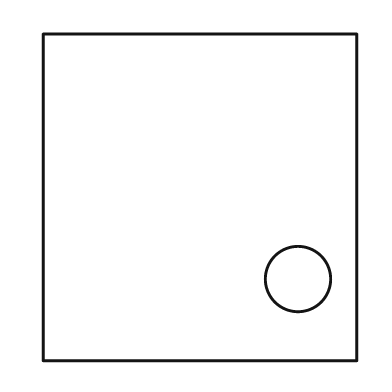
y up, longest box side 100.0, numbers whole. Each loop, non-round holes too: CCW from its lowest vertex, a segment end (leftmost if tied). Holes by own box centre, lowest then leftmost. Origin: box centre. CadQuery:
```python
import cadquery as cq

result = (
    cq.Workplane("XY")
    .moveTo(-48.0, -50.0)
    .lineTo(48.0, -50.0)
    .lineTo(48.0, 50.0)
    .lineTo(-48.0, 50.0)
    .close()
    .moveTo(30.0, -25.0)
    .circle(10.0)
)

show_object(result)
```